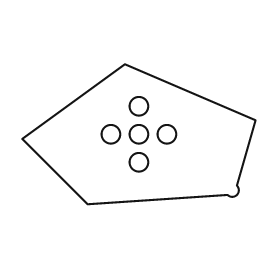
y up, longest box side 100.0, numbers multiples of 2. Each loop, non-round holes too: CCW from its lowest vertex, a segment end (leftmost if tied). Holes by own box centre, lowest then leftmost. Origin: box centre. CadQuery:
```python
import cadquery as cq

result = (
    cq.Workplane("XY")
    .moveTo(-22.0, -30.0)
    .lineTo(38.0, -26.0)
    .threePointArc((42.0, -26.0), (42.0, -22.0))
    .lineTo(50.0, 6.0)
    .lineTo(-6.0, 30.0)
    .lineTo(-50.0, -2.0)
    .close()
    .moveTo(0.0, -12.0)
    .circle(4.0)
    .moveTo(-12.0, 0.0)
    .circle(4.0)
    .moveTo(0.0, 0.0)
    .circle(4.0)
    .moveTo(12.0, 0.0)
    .circle(4.0)
    .moveTo(0.0, 12.0)
    .circle(4.0)
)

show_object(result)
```